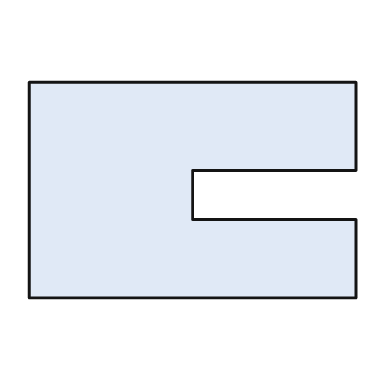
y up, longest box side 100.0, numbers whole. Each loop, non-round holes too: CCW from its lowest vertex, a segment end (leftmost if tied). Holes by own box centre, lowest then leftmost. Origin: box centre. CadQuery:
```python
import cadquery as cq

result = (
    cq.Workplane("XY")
    .moveTo(-50.0, -33.0)
    .lineTo(50.0, -33.0)
    .lineTo(50.0, -9.0)
    .lineTo(0.0, -9.0)
    .lineTo(0.0, 6.0)
    .lineTo(50.0, 6.0)
    .lineTo(50.0, 33.0)
    .lineTo(-50.0, 33.0)
    .close()
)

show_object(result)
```